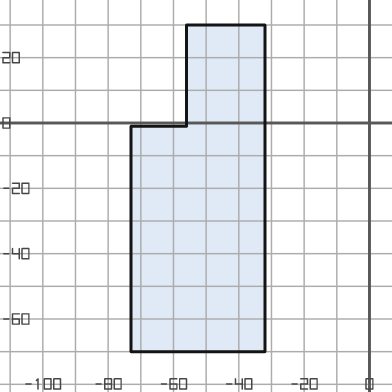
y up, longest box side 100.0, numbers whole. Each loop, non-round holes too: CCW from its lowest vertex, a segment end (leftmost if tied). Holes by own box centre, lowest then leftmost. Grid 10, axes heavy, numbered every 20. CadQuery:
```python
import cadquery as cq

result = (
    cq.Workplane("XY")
    .moveTo(-73.0, -70.0)
    .lineTo(-32.0, -70.0)
    .lineTo(-32.0, 30.0)
    .lineTo(-56.0, 30.0)
    .lineTo(-56.0, -1.0)
    .lineTo(-73.0, -1.0)
    .close()
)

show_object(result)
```